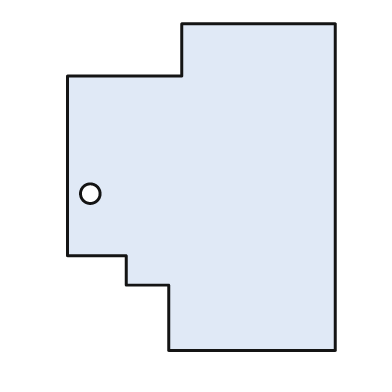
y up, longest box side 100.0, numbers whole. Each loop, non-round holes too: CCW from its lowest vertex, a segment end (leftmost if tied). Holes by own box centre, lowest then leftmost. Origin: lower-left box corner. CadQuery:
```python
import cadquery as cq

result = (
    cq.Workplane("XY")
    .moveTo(31.0, 0.0)
    .lineTo(82.0, 0.0)
    .lineTo(82.0, 100.0)
    .lineTo(35.0, 100.0)
    .lineTo(35.0, 84.0)
    .lineTo(0.0, 84.0)
    .lineTo(0.0, 29.0)
    .lineTo(18.0, 29.0)
    .lineTo(18.0, 20.0)
    .lineTo(31.0, 20.0)
    .close()
    .moveTo(7.0, 48.0)
    .circle(3.0)
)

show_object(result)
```